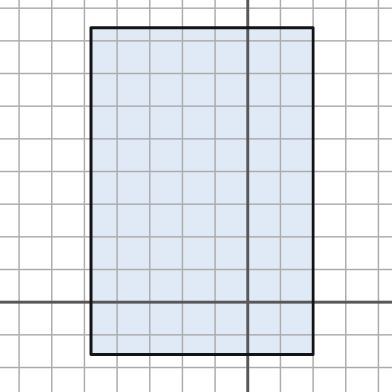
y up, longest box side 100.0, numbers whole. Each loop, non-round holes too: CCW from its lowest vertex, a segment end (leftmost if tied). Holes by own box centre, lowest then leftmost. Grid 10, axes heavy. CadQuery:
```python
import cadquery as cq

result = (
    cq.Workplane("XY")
    .moveTo(-48.0, -16.0)
    .lineTo(20.0, -16.0)
    .lineTo(20.0, 84.0)
    .lineTo(-48.0, 84.0)
    .close()
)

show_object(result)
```